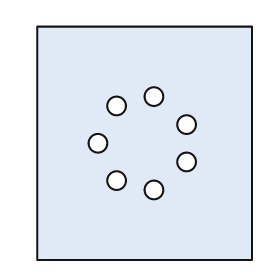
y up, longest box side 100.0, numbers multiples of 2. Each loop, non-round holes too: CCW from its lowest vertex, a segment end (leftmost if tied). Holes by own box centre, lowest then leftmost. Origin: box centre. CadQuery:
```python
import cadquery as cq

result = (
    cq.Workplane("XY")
    .moveTo(-46.0, -50.0)
    .lineTo(46.0, -50.0)
    .lineTo(46.0, 50.0)
    .lineTo(-46.0, 50.0)
    .close()
    .moveTo(4.0, -20.0)
    .circle(4.0)
    .moveTo(-12.0, -16.0)
    .circle(4.0)
    .moveTo(18.0, -8.0)
    .circle(4.0)
    .moveTo(-20.0, 0.0)
    .circle(4.0)
    .moveTo(18.0, 8.0)
    .circle(4.0)
    .moveTo(-12.0, 16.0)
    .circle(4.0)
    .moveTo(4.0, 20.0)
    .circle(4.0)
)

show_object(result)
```